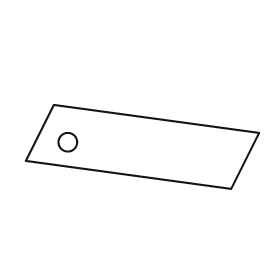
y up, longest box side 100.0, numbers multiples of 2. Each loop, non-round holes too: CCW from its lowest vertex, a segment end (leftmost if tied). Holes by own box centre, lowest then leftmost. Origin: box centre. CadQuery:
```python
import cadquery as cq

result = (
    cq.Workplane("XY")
    .moveTo(38.0, -18.0)
    .lineTo(50.0, 6.0)
    .lineTo(-38.0, 18.0)
    .lineTo(-50.0, -6.0)
    .close()
    .moveTo(-32.0, 2.0)
    .circle(4.0)
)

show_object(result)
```